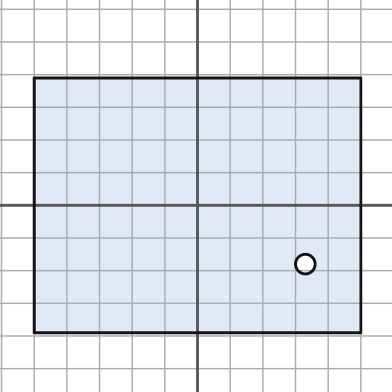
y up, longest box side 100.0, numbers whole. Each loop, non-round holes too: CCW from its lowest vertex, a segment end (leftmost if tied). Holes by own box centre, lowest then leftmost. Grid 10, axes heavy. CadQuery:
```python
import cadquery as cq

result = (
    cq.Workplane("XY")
    .moveTo(-50.0, -39.0)
    .lineTo(50.0, -39.0)
    .lineTo(50.0, 39.0)
    .lineTo(-50.0, 39.0)
    .close()
    .moveTo(33.0, -18.0)
    .circle(3.0)
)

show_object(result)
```